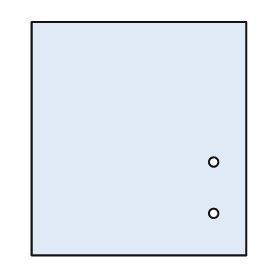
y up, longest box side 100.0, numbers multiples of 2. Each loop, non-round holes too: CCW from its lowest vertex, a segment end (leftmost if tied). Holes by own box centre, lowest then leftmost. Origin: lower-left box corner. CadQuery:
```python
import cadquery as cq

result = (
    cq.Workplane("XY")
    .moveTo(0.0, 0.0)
    .lineTo(92.0, 0.0)
    .lineTo(92.0, 100.0)
    .lineTo(0.0, 100.0)
    .close()
    .moveTo(78.0, 18.0)
    .circle(2.0)
    .moveTo(78.0, 40.0)
    .circle(2.0)
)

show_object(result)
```